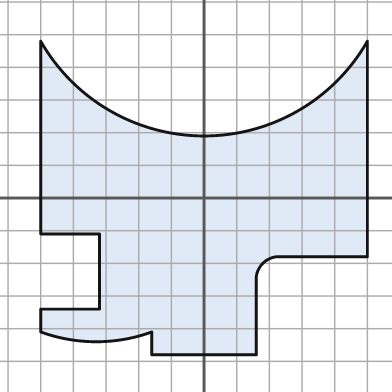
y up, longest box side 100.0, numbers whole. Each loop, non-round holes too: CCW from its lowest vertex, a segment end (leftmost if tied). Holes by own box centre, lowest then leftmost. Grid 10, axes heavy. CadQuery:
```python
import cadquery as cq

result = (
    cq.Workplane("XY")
    .moveTo(-16.0, -48.0)
    .lineTo(16.0, -48.0)
    .lineTo(16.0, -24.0)
    .threePointArc((18.0, -20.0), (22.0, -18.0))
    .lineTo(50.0, -18.0)
    .lineTo(50.0, 48.0)
    .threePointArc((0.0, 19.0), (-50.0, 48.0))
    .lineTo(-50.0, -11.0)
    .lineTo(-32.0, -11.0)
    .lineTo(-32.0, -34.0)
    .lineTo(-50.0, -34.0)
    .lineTo(-50.0, -41.0)
    .threePointArc((-33.0, -44.0), (-16.0, -41.0))
    .close()
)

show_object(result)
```